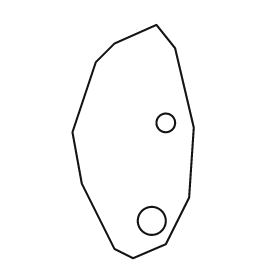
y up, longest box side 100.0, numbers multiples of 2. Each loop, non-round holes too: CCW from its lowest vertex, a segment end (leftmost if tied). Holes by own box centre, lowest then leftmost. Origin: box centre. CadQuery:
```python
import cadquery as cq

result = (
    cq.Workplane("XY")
    .moveTo(0.0, -50.0)
    .lineTo(14.0, -44.0)
    .lineTo(24.0, -24.0)
    .lineTo(26.0, 6.0)
    .lineTo(18.0, 40.0)
    .lineTo(10.0, 50.0)
    .lineTo(-8.0, 42.0)
    .lineTo(-16.0, 34.0)
    .lineTo(-26.0, 4.0)
    .lineTo(-22.0, -18.0)
    .lineTo(-8.0, -46.0)
    .close()
    .moveTo(8.0, -34.0)
    .circle(6.0)
    .moveTo(14.0, 8.0)
    .circle(4.0)
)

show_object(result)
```